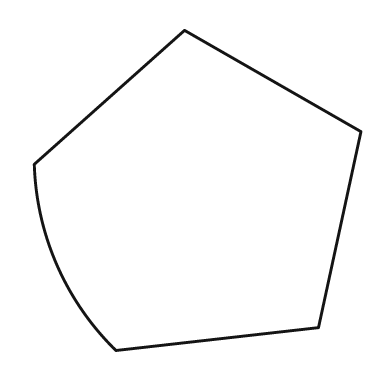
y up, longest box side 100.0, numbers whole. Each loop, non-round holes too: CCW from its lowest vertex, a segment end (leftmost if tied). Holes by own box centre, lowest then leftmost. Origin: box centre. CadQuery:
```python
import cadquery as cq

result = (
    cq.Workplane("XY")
    .moveTo(-25.0, -49.0)
    .lineTo(37.0, -42.0)
    .lineTo(50.0, 18.0)
    .lineTo(-4.0, 49.0)
    .lineTo(-50.0, 8.0)
    .threePointArc((-43.0, -23.0), (-25.0, -49.0))
    .close()
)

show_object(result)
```